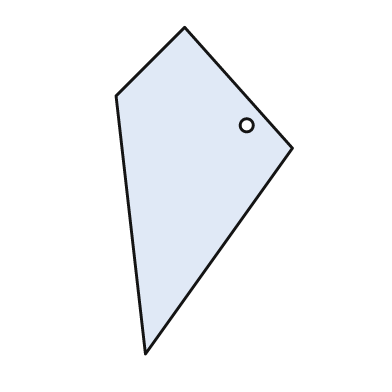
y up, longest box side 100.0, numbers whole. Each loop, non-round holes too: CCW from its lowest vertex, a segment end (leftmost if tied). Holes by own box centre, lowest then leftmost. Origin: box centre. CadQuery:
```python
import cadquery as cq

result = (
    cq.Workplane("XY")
    .moveTo(-18.0, -50.0)
    .lineTo(27.0, 13.0)
    .lineTo(-6.0, 50.0)
    .lineTo(-27.0, 29.0)
    .close()
    .moveTo(13.0, 20.0)
    .circle(2.0)
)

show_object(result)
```